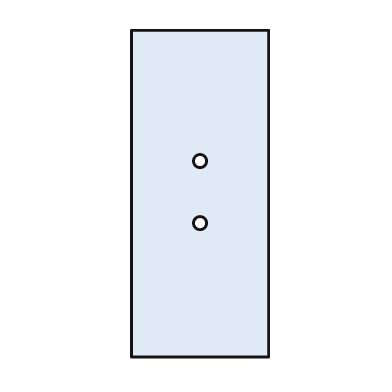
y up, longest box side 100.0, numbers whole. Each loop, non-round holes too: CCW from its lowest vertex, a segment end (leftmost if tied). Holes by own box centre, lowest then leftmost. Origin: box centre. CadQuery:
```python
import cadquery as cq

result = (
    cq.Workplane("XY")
    .moveTo(-21.0, -50.0)
    .lineTo(21.0, -50.0)
    .lineTo(21.0, 50.0)
    .lineTo(-21.0, 50.0)
    .close()
    .moveTo(0.0, -9.0)
    .circle(2.0)
    .moveTo(0.0, 10.0)
    .circle(2.0)
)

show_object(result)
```